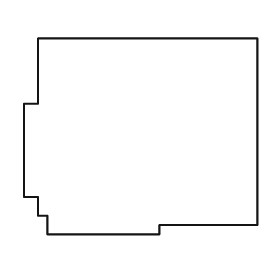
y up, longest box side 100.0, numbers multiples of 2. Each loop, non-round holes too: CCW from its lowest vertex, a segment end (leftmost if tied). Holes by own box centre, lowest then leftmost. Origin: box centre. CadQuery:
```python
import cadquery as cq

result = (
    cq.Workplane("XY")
    .moveTo(-40.0, -42.0)
    .lineTo(8.0, -42.0)
    .lineTo(8.0, -38.0)
    .lineTo(50.0, -38.0)
    .lineTo(50.0, 42.0)
    .lineTo(-44.0, 42.0)
    .lineTo(-44.0, 14.0)
    .lineTo(-50.0, 14.0)
    .lineTo(-50.0, -26.0)
    .lineTo(-44.0, -26.0)
    .lineTo(-44.0, -34.0)
    .lineTo(-40.0, -34.0)
    .close()
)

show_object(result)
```